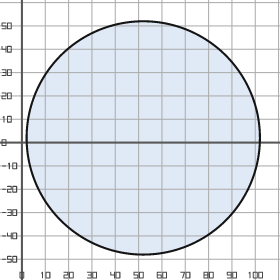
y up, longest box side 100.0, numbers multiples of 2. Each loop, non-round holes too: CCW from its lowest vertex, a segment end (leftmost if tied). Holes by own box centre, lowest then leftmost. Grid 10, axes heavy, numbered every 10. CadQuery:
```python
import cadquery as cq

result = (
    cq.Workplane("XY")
    .moveTo(52.0, 2.0)
    .circle(50.0)
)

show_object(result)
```